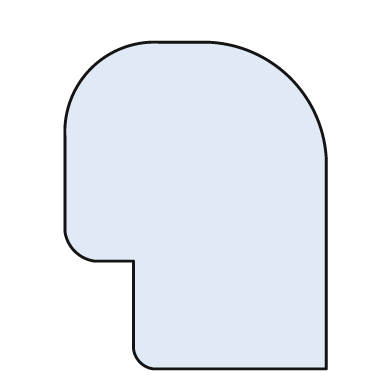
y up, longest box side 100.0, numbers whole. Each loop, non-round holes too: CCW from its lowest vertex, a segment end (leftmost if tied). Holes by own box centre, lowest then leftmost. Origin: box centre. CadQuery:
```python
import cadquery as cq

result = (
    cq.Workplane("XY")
    .moveTo(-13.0, -50.0)
    .lineTo(40.0, -50.0)
    .lineTo(40.0, 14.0)
    .threePointArc((29.0, 39.0), (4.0, 50.0))
    .lineTo(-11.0, 50.0)
    .threePointArc((-32.0, 42.0), (-40.0, 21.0))
    .lineTo(-40.0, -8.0)
    .threePointArc((-37.0, -14.0), (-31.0, -17.0))
    .lineTo(-19.0, -17.0)
    .lineTo(-19.0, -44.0)
    .threePointArc((-17.0, -48.0), (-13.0, -50.0))
    .close()
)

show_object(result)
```